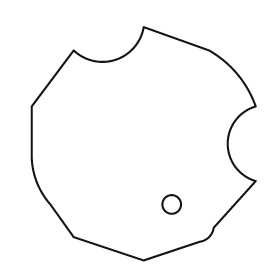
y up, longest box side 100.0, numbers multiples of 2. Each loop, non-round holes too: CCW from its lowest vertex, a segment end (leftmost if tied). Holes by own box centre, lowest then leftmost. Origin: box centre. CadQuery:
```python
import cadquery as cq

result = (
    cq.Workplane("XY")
    .moveTo(0.0, -50.0)
    .lineTo(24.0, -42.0)
    .threePointArc((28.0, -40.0), (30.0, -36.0))
    .lineTo(48.0, -16.0)
    .threePointArc((36.0, 0.0), (48.0, 16.0))
    .threePointArc((40.0, 30.0), (28.0, 40.0))
    .lineTo(0.0, 50.0)
    .threePointArc((-12.0, 36.0), (-30.0, 40.0))
    .lineTo(-48.0, 16.0)
    .lineTo(-48.0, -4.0)
    .threePointArc((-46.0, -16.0), (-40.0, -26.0))
    .lineTo(-30.0, -40.0)
    .close()
    .moveTo(12.0, -26.0)
    .circle(4.0)
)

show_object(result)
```